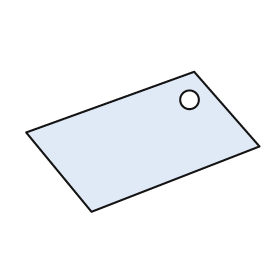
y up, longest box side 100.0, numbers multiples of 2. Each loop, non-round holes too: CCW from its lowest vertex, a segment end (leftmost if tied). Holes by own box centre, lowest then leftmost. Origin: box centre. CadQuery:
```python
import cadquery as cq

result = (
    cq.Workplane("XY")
    .moveTo(-22.0, -30.0)
    .lineTo(50.0, -2.0)
    .lineTo(22.0, 30.0)
    .lineTo(-50.0, 4.0)
    .close()
    .moveTo(20.0, 18.0)
    .circle(4.0)
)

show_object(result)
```